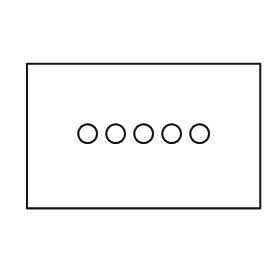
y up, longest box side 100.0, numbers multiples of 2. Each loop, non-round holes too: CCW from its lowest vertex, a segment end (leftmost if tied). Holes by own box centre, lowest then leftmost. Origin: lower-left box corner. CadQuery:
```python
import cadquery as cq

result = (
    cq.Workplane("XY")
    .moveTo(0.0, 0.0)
    .lineTo(100.0, 0.0)
    .lineTo(100.0, 62.0)
    .lineTo(0.0, 62.0)
    .close()
    .moveTo(26.0, 32.0)
    .circle(4.0)
    .moveTo(38.0, 32.0)
    .circle(4.0)
    .moveTo(50.0, 32.0)
    .circle(4.0)
    .moveTo(62.0, 32.0)
    .circle(4.0)
    .moveTo(74.0, 32.0)
    .circle(4.0)
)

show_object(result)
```